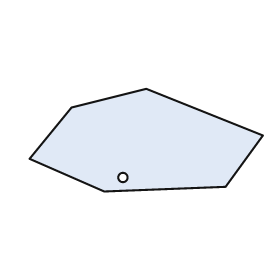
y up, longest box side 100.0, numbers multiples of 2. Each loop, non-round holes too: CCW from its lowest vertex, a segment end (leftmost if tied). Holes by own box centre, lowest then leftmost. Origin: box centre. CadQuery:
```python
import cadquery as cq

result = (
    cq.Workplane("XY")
    .moveTo(-18.0, -22.0)
    .lineTo(34.0, -20.0)
    .lineTo(50.0, 2.0)
    .lineTo(0.0, 22.0)
    .lineTo(-32.0, 14.0)
    .lineTo(-50.0, -8.0)
    .close()
    .moveTo(-10.0, -16.0)
    .circle(2.0)
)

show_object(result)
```